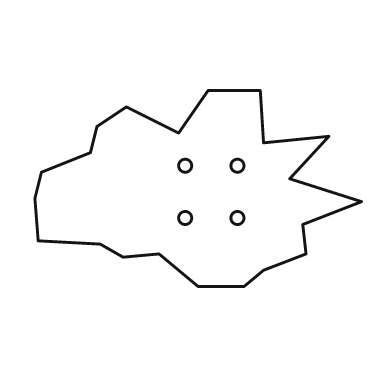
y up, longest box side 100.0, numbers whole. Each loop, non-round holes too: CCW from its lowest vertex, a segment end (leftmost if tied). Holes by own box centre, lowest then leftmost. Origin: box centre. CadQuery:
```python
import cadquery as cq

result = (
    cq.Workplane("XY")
    .moveTo(0.0, -30.0)
    .lineTo(14.0, -30.0)
    .lineTo(20.0, -25.0)
    .lineTo(33.0, -20.0)
    .lineTo(32.0, -11.0)
    .lineTo(50.0, -4.0)
    .lineTo(28.0, 3.0)
    .lineTo(40.0, 16.0)
    .lineTo(20.0, 14.0)
    .lineTo(19.0, 30.0)
    .lineTo(3.0, 30.0)
    .lineTo(-6.0, 17.0)
    .lineTo(-22.0, 25.0)
    .lineTo(-31.0, 19.0)
    .lineTo(-33.0, 11.0)
    .lineTo(-48.0, 5.0)
    .lineTo(-50.0, -3.0)
    .lineTo(-49.0, -16.0)
    .lineTo(-30.0, -17.0)
    .lineTo(-23.0, -21.0)
    .lineTo(-12.0, -20.0)
    .close()
    .moveTo(-4.0, -9.0)
    .circle(2.0)
    .moveTo(12.0, -9.0)
    .circle(2.0)
    .moveTo(-4.0, 7.0)
    .circle(2.0)
    .moveTo(12.0, 7.0)
    .circle(2.0)
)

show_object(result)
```